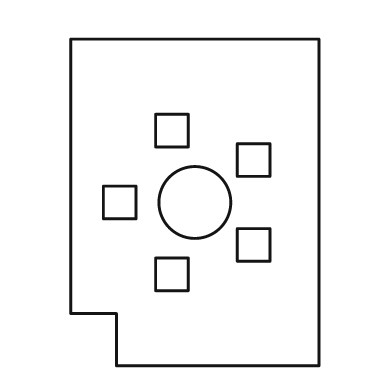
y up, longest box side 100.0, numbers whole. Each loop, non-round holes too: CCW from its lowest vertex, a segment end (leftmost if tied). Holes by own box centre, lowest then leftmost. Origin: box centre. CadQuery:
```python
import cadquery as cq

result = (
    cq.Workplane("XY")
    .moveTo(-24.0, -50.0)
    .lineTo(38.0, -50.0)
    .lineTo(38.0, 50.0)
    .lineTo(-38.0, 50.0)
    .lineTo(-38.0, -34.0)
    .lineTo(-24.0, -34.0)
    .close()
    .moveTo(-12.0, -27.0)
    .lineTo(-2.0, -27.0)
    .lineTo(-2.0, -17.0)
    .lineTo(-12.0, -17.0)
    .close()
    .moveTo(13.0, -18.0)
    .lineTo(23.0, -18.0)
    .lineTo(23.0, -8.0)
    .lineTo(13.0, -8.0)
    .close()
    .moveTo(-28.0, -5.0)
    .lineTo(-18.0, -5.0)
    .lineTo(-18.0, 5.0)
    .lineTo(-28.0, 5.0)
    .close()
    .moveTo(0.0, 0.0)
    .circle(11.0)
    .moveTo(13.0, 8.0)
    .lineTo(23.0, 8.0)
    .lineTo(23.0, 18.0)
    .lineTo(13.0, 18.0)
    .close()
    .moveTo(-12.0, 17.0)
    .lineTo(-2.0, 17.0)
    .lineTo(-2.0, 27.0)
    .lineTo(-12.0, 27.0)
    .close()
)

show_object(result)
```